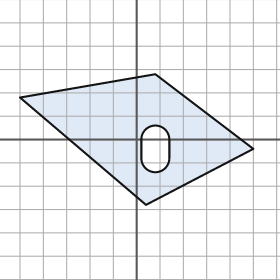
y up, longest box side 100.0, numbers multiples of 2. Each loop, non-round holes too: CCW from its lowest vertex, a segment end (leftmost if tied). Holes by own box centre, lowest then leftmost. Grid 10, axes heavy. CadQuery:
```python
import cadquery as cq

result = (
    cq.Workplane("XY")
    .moveTo(4.0, -28.0)
    .lineTo(50.0, -4.0)
    .lineTo(8.0, 28.0)
    .lineTo(-50.0, 18.0)
    .close()
    .moveTo(2.0, -8.0)
    .threePointArc((8.0, -14.0), (14.0, -8.0))
    .lineTo(14.0, 0.0)
    .threePointArc((8.0, 6.0), (2.0, 0.0))
    .close()
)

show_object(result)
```